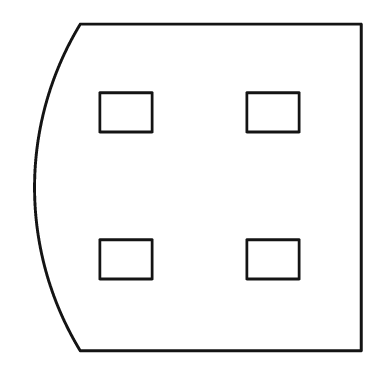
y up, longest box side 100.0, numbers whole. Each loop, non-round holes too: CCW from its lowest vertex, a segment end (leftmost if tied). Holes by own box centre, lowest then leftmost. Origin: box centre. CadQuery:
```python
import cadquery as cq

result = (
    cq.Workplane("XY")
    .moveTo(-36.0, -50.0)
    .lineTo(50.0, -50.0)
    .lineTo(50.0, 50.0)
    .lineTo(-36.0, 50.0)
    .threePointArc((-50.0, 0.0), (-36.0, -50.0))
    .close()
    .moveTo(-30.0, -28.0)
    .lineTo(-14.0, -28.0)
    .lineTo(-14.0, -16.0)
    .lineTo(-30.0, -16.0)
    .close()
    .moveTo(15.0, -28.0)
    .lineTo(31.0, -28.0)
    .lineTo(31.0, -16.0)
    .lineTo(15.0, -16.0)
    .close()
    .moveTo(-30.0, 17.0)
    .lineTo(-14.0, 17.0)
    .lineTo(-14.0, 29.0)
    .lineTo(-30.0, 29.0)
    .close()
    .moveTo(15.0, 17.0)
    .lineTo(31.0, 17.0)
    .lineTo(31.0, 29.0)
    .lineTo(15.0, 29.0)
    .close()
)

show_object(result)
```